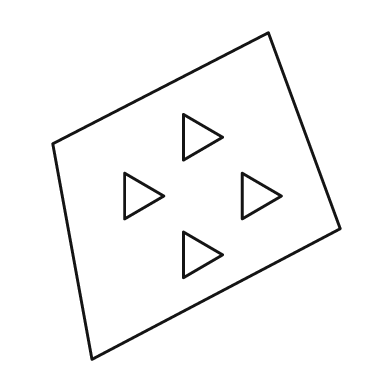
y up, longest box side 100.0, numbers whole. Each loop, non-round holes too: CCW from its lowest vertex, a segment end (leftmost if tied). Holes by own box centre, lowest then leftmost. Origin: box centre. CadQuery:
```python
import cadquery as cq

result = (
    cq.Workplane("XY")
    .moveTo(-32.0, -50.0)
    .lineTo(44.0, -10.0)
    .lineTo(22.0, 50.0)
    .lineTo(-44.0, 16.0)
    .close()
    .moveTo(-4.0, -25.0)
    .lineTo(8.0, -18.0)
    .lineTo(-4.0, -11.0)
    .close()
    .moveTo(-22.0, -7.0)
    .lineTo(-10.0, 0.0)
    .lineTo(-22.0, 7.0)
    .close()
    .moveTo(14.0, -7.0)
    .lineTo(26.0, 0.0)
    .lineTo(14.0, 7.0)
    .close()
    .moveTo(-4.0, 11.0)
    .lineTo(8.0, 18.0)
    .lineTo(-4.0, 25.0)
    .close()
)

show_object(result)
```